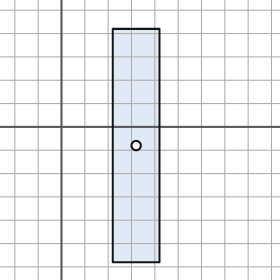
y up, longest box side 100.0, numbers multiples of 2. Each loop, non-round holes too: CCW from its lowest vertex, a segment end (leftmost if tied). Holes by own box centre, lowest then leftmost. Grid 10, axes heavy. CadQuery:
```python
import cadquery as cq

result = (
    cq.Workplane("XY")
    .moveTo(22.0, -58.0)
    .lineTo(42.0, -58.0)
    .lineTo(42.0, 42.0)
    .lineTo(22.0, 42.0)
    .close()
    .moveTo(32.0, -8.0)
    .circle(2.0)
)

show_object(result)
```